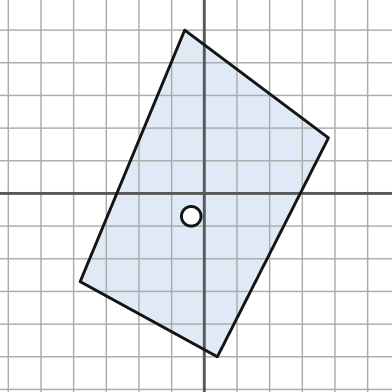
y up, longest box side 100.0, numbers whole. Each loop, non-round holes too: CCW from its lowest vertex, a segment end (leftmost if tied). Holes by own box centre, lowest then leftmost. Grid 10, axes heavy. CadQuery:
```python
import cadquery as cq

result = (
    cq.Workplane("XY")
    .moveTo(4.0, -50.0)
    .lineTo(38.0, 17.0)
    .lineTo(-6.0, 50.0)
    .lineTo(-38.0, -27.0)
    .close()
    .moveTo(-4.0, -7.0)
    .circle(3.0)
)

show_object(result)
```